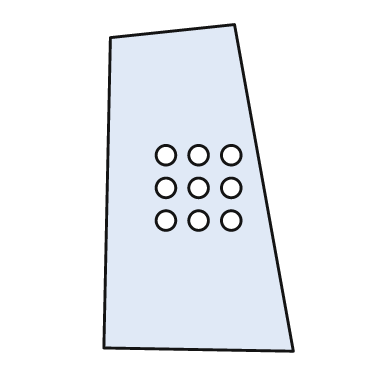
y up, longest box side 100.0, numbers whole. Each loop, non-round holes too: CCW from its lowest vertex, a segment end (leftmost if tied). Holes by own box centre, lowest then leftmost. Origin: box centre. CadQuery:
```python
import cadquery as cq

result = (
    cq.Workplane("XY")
    .moveTo(29.0, -50.0)
    .lineTo(11.0, 50.0)
    .lineTo(-27.0, 46.0)
    .lineTo(-29.0, -49.0)
    .close()
    .moveTo(-10.0, -10.0)
    .circle(3.0)
    .moveTo(0.0, -10.0)
    .circle(3.0)
    .moveTo(10.0, -10.0)
    .circle(3.0)
    .moveTo(-10.0, 0.0)
    .circle(3.0)
    .moveTo(0.0, 0.0)
    .circle(3.0)
    .moveTo(10.0, 0.0)
    .circle(3.0)
    .moveTo(-10.0, 10.0)
    .circle(3.0)
    .moveTo(0.0, 10.0)
    .circle(3.0)
    .moveTo(10.0, 10.0)
    .circle(3.0)
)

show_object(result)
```